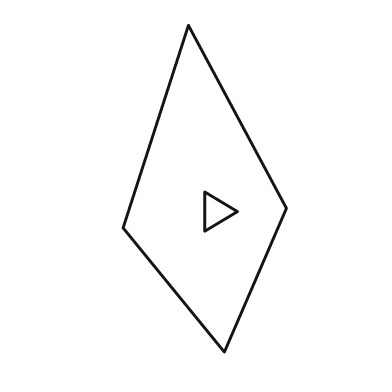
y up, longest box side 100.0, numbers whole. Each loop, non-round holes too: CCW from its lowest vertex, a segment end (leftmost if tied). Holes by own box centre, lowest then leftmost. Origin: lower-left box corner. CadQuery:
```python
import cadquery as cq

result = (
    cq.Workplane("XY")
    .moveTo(31.0, 0.0)
    .lineTo(50.0, 44.0)
    .lineTo(20.0, 100.0)
    .lineTo(0.0, 38.0)
    .close()
    .moveTo(25.0, 37.0)
    .lineTo(35.0, 43.0)
    .lineTo(25.0, 49.0)
    .close()
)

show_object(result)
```